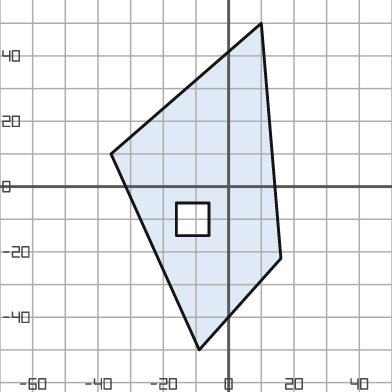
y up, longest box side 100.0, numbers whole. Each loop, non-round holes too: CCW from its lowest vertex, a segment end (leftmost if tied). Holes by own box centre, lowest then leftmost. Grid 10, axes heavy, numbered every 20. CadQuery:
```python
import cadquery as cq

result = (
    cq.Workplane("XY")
    .moveTo(-9.0, -50.0)
    .lineTo(16.0, -22.0)
    .lineTo(10.0, 50.0)
    .lineTo(-36.0, 10.0)
    .close()
    .moveTo(-16.0, -15.0)
    .lineTo(-6.0, -15.0)
    .lineTo(-6.0, -5.0)
    .lineTo(-16.0, -5.0)
    .close()
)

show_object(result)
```